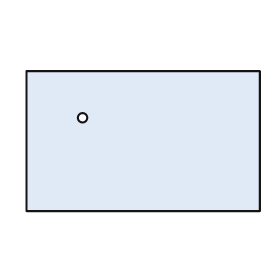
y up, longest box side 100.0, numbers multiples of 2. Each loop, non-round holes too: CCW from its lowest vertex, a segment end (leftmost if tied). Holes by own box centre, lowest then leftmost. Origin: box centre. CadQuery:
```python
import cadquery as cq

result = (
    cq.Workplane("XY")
    .moveTo(-50.0, -30.0)
    .lineTo(50.0, -30.0)
    .lineTo(50.0, 30.0)
    .lineTo(-50.0, 30.0)
    .close()
    .moveTo(-26.0, 10.0)
    .circle(2.0)
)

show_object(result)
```